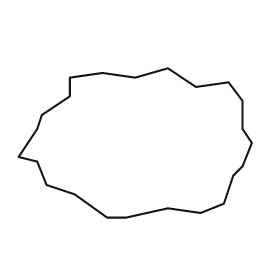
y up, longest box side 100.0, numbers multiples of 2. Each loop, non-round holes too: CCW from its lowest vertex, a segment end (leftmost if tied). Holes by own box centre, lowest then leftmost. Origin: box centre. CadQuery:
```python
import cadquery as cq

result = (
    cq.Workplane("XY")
    .moveTo(-12.0, -32.0)
    .lineTo(-4.0, -32.0)
    .lineTo(14.0, -28.0)
    .lineTo(28.0, -30.0)
    .lineTo(38.0, -26.0)
    .lineTo(42.0, -14.0)
    .lineTo(46.0, -10.0)
    .lineTo(50.0, 0.0)
    .lineTo(46.0, 6.0)
    .lineTo(46.0, 18.0)
    .lineTo(40.0, 26.0)
    .lineTo(26.0, 24.0)
    .lineTo(14.0, 32.0)
    .lineTo(0.0, 28.0)
    .lineTo(-14.0, 30.0)
    .lineTo(-28.0, 28.0)
    .lineTo(-28.0, 20.0)
    .lineTo(-40.0, 12.0)
    .lineTo(-42.0, 6.0)
    .lineTo(-50.0, -6.0)
    .lineTo(-42.0, -8.0)
    .lineTo(-38.0, -18.0)
    .lineTo(-26.0, -22.0)
    .close()
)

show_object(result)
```